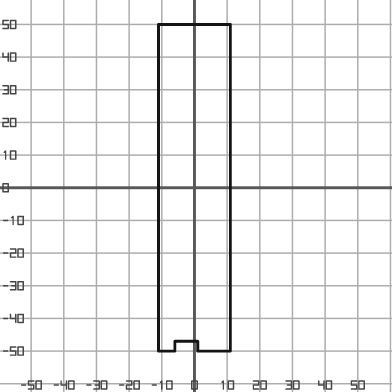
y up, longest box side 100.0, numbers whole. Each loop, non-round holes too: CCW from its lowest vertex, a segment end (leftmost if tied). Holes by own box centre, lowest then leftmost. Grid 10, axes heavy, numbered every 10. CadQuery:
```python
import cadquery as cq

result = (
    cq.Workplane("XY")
    .moveTo(-11.0, -50.0)
    .lineTo(-6.0, -50.0)
    .lineTo(-6.0, -47.0)
    .lineTo(1.0, -47.0)
    .lineTo(1.0, -50.0)
    .lineTo(11.0, -50.0)
    .lineTo(11.0, 50.0)
    .lineTo(-11.0, 50.0)
    .close()
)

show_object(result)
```